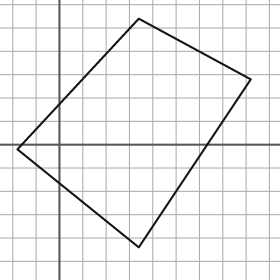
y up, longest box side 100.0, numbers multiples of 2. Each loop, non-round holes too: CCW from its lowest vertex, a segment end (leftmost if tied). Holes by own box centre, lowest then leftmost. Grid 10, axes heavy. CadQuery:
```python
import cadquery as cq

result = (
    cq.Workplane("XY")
    .moveTo(34.0, -44.0)
    .lineTo(82.0, 28.0)
    .lineTo(34.0, 54.0)
    .lineTo(-18.0, -2.0)
    .close()
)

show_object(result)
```